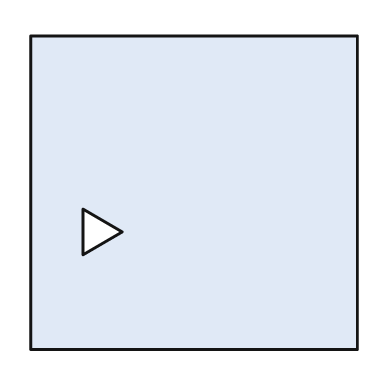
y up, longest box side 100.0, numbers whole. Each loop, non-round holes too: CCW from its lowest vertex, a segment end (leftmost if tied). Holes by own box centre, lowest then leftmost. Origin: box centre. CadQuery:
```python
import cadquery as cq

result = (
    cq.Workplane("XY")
    .moveTo(-50.0, -48.0)
    .lineTo(50.0, -48.0)
    .lineTo(50.0, 48.0)
    .lineTo(-50.0, 48.0)
    .close()
    .moveTo(-34.0, -19.0)
    .lineTo(-22.0, -12.0)
    .lineTo(-34.0, -5.0)
    .close()
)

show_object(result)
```